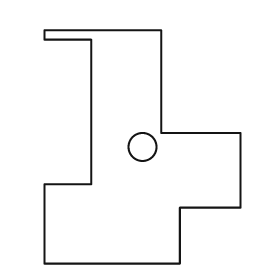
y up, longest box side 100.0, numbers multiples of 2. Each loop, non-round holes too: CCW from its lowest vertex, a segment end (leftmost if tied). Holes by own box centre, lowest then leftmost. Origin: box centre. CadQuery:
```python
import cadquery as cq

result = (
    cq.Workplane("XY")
    .moveTo(-42.0, -50.0)
    .lineTo(16.0, -50.0)
    .lineTo(16.0, -26.0)
    .lineTo(42.0, -26.0)
    .lineTo(42.0, 6.0)
    .lineTo(8.0, 6.0)
    .lineTo(8.0, 50.0)
    .lineTo(-42.0, 50.0)
    .lineTo(-42.0, 46.0)
    .lineTo(-22.0, 46.0)
    .lineTo(-22.0, -16.0)
    .lineTo(-42.0, -16.0)
    .close()
    .moveTo(0.0, 0.0)
    .circle(6.0)
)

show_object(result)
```